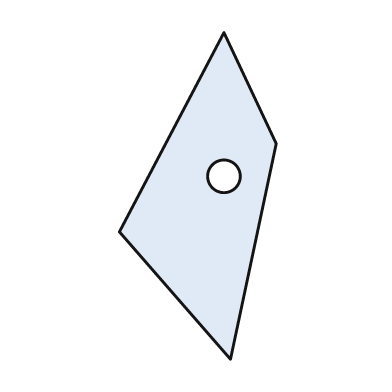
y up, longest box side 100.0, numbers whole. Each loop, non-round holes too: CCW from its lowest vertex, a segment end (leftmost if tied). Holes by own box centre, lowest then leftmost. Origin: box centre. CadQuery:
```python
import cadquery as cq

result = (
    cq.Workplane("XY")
    .moveTo(10.0, -50.0)
    .lineTo(24.0, 16.0)
    .lineTo(8.0, 50.0)
    .lineTo(-24.0, -11.0)
    .close()
    .moveTo(8.0, 6.0)
    .circle(5.0)
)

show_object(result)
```